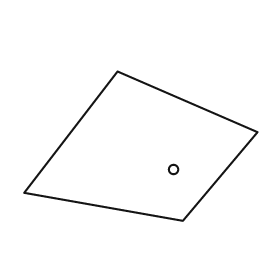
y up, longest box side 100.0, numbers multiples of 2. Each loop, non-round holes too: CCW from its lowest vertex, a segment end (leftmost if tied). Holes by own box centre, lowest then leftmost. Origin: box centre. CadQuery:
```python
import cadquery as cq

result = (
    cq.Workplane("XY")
    .moveTo(18.0, -32.0)
    .lineTo(50.0, 6.0)
    .lineTo(-10.0, 32.0)
    .lineTo(-50.0, -20.0)
    .close()
    .moveTo(14.0, -10.0)
    .circle(2.0)
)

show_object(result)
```